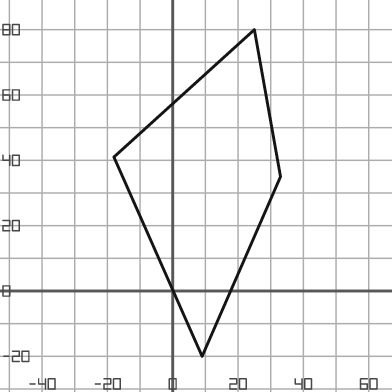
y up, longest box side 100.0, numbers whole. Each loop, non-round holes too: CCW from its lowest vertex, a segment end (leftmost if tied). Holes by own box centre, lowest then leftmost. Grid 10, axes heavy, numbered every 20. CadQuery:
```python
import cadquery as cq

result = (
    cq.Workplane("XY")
    .moveTo(9.0, -20.0)
    .lineTo(33.0, 35.0)
    .lineTo(25.0, 80.0)
    .lineTo(-18.0, 41.0)
    .close()
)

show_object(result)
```